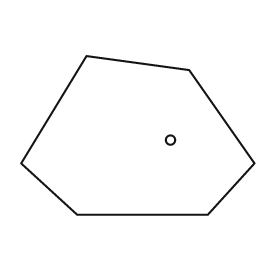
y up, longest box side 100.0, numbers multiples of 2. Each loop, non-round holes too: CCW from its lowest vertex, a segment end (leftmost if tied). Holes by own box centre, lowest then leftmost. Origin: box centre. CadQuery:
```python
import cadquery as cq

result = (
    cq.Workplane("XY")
    .moveTo(-26.0, -34.0)
    .lineTo(30.0, -34.0)
    .lineTo(50.0, -12.0)
    .lineTo(22.0, 28.0)
    .lineTo(-22.0, 34.0)
    .lineTo(-50.0, -12.0)
    .close()
    .moveTo(14.0, -2.0)
    .circle(2.0)
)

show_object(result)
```